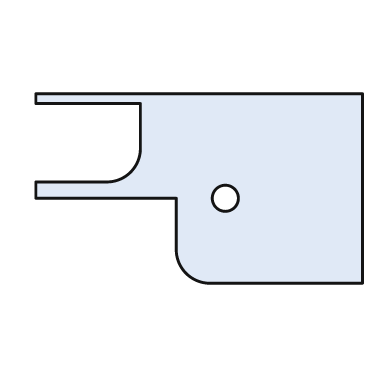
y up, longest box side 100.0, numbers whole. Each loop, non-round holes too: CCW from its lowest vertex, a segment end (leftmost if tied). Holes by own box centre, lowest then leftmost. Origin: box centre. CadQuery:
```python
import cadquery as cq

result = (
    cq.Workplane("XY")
    .moveTo(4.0, -29.0)
    .lineTo(50.0, -29.0)
    .lineTo(50.0, 29.0)
    .lineTo(-50.0, 29.0)
    .lineTo(-50.0, 26.0)
    .lineTo(-18.0, 26.0)
    .lineTo(-18.0, 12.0)
    .threePointArc((-21.0, 5.0), (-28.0, 2.0))
    .lineTo(-50.0, 2.0)
    .lineTo(-50.0, -3.0)
    .lineTo(-7.0, -3.0)
    .lineTo(-7.0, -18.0)
    .threePointArc((-4.0, -26.0), (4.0, -29.0))
    .close()
    .moveTo(8.0, -3.0)
    .circle(4.0)
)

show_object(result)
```